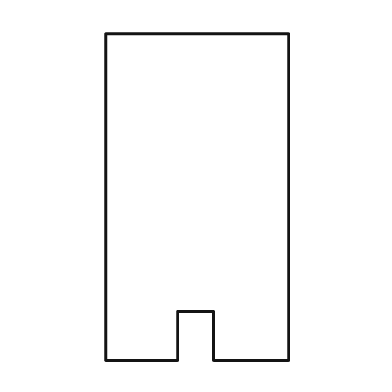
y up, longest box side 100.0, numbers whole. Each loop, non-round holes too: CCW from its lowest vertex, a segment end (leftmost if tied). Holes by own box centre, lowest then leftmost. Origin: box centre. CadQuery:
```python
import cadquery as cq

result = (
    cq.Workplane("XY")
    .moveTo(-28.0, -50.0)
    .lineTo(-6.0, -50.0)
    .lineTo(-6.0, -35.0)
    .lineTo(5.0, -35.0)
    .lineTo(5.0, -50.0)
    .lineTo(28.0, -50.0)
    .lineTo(28.0, 50.0)
    .lineTo(-28.0, 50.0)
    .close()
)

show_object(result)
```